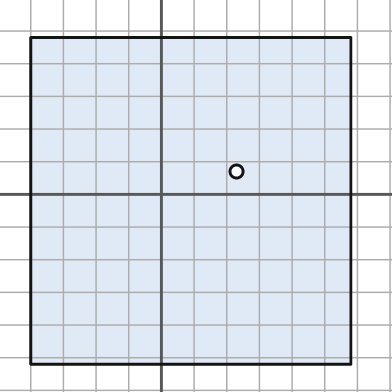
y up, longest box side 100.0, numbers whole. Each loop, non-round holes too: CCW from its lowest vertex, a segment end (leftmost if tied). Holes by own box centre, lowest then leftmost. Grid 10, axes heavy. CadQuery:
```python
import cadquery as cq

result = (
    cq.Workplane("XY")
    .moveTo(-40.0, -52.0)
    .lineTo(58.0, -52.0)
    .lineTo(58.0, 48.0)
    .lineTo(-40.0, 48.0)
    .close()
    .moveTo(23.0, 7.0)
    .circle(2.0)
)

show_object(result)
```